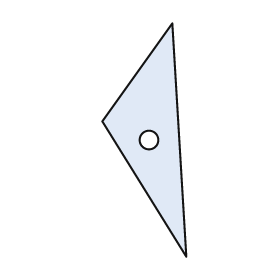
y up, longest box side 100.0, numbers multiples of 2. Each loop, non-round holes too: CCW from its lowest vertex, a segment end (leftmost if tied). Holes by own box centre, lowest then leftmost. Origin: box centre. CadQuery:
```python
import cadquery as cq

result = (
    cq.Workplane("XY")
    .moveTo(18.0, -50.0)
    .lineTo(12.0, 50.0)
    .lineTo(-18.0, 8.0)
    .close()
    .moveTo(2.0, 0.0)
    .circle(4.0)
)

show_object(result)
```